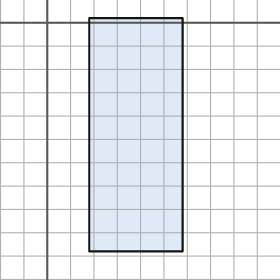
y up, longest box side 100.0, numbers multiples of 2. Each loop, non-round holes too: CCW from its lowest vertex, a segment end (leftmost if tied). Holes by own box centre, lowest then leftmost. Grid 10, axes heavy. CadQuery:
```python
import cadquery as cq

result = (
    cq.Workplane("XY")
    .moveTo(18.0, -98.0)
    .lineTo(58.0, -98.0)
    .lineTo(58.0, 2.0)
    .lineTo(18.0, 2.0)
    .close()
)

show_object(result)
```